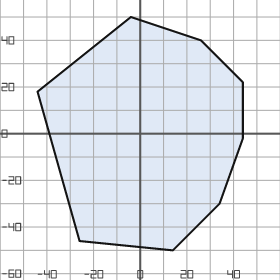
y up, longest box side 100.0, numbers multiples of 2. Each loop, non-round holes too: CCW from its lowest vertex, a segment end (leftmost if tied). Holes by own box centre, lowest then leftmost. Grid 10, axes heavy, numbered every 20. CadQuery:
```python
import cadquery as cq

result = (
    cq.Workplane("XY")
    .moveTo(14.0, -50.0)
    .lineTo(34.0, -30.0)
    .lineTo(44.0, -2.0)
    .lineTo(44.0, 22.0)
    .lineTo(26.0, 40.0)
    .lineTo(-4.0, 50.0)
    .lineTo(-44.0, 18.0)
    .lineTo(-26.0, -46.0)
    .close()
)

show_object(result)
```